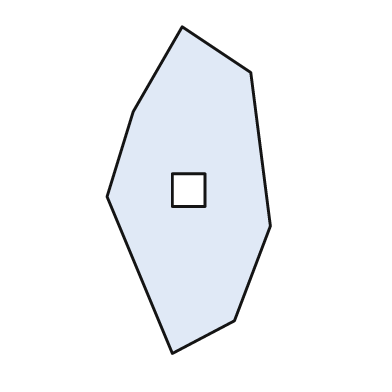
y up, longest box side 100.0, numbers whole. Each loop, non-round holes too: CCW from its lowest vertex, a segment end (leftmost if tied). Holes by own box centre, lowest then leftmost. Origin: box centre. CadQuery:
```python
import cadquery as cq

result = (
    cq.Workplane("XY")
    .moveTo(-5.0, -50.0)
    .lineTo(14.0, -40.0)
    .lineTo(25.0, -11.0)
    .lineTo(19.0, 36.0)
    .lineTo(-2.0, 50.0)
    .lineTo(-17.0, 24.0)
    .lineTo(-25.0, -2.0)
    .close()
    .moveTo(-5.0, -5.0)
    .lineTo(5.0, -5.0)
    .lineTo(5.0, 5.0)
    .lineTo(-5.0, 5.0)
    .close()
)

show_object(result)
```